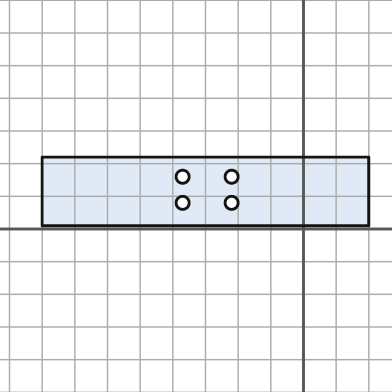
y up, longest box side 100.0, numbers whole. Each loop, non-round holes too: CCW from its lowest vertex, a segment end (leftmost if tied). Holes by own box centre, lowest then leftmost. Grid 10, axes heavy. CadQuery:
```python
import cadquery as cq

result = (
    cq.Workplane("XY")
    .moveTo(-80.0, 1.0)
    .lineTo(20.0, 1.0)
    .lineTo(20.0, 22.0)
    .lineTo(-80.0, 22.0)
    .close()
    .moveTo(-37.0, 8.0)
    .circle(2.0)
    .moveTo(-22.0, 8.0)
    .circle(2.0)
    .moveTo(-37.0, 16.0)
    .circle(2.0)
    .moveTo(-22.0, 16.0)
    .circle(2.0)
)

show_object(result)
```